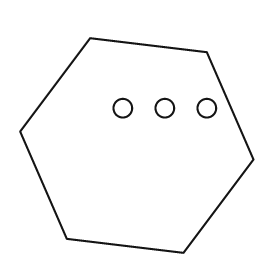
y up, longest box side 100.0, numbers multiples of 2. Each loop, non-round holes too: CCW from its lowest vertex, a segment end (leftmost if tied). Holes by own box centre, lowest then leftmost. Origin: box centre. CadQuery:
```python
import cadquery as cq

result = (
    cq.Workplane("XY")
    .moveTo(20.0, -46.0)
    .lineTo(50.0, -6.0)
    .lineTo(30.0, 40.0)
    .lineTo(-20.0, 46.0)
    .lineTo(-50.0, 6.0)
    .lineTo(-30.0, -40.0)
    .close()
    .moveTo(-6.0, 16.0)
    .circle(4.0)
    .moveTo(12.0, 16.0)
    .circle(4.0)
    .moveTo(30.0, 16.0)
    .circle(4.0)
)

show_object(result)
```